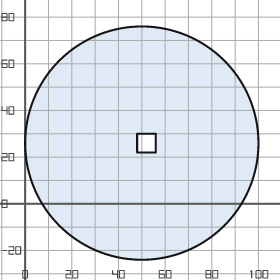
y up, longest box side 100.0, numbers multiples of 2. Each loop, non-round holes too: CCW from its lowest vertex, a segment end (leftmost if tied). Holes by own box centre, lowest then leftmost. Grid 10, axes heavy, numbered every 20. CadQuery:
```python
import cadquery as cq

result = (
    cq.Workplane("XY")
    .moveTo(50.0, 26.0)
    .circle(50.0)
    .moveTo(48.0, 22.0)
    .lineTo(56.0, 22.0)
    .lineTo(56.0, 30.0)
    .lineTo(48.0, 30.0)
    .close()
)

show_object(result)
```